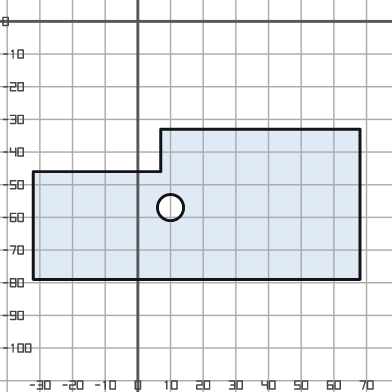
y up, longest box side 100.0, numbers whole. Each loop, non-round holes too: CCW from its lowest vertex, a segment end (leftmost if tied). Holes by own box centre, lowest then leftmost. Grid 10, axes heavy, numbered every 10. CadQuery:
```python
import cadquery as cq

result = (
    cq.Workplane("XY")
    .moveTo(-32.0, -79.0)
    .lineTo(68.0, -79.0)
    .lineTo(68.0, -33.0)
    .lineTo(7.0, -33.0)
    .lineTo(7.0, -46.0)
    .lineTo(-32.0, -46.0)
    .close()
    .moveTo(10.0, -57.0)
    .circle(4.0)
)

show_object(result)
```